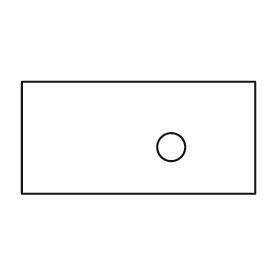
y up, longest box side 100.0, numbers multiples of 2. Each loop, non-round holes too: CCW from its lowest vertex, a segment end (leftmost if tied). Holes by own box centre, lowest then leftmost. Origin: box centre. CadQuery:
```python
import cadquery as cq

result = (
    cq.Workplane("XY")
    .moveTo(-50.0, -24.0)
    .lineTo(50.0, -24.0)
    .lineTo(50.0, 24.0)
    .lineTo(-50.0, 24.0)
    .close()
    .moveTo(14.0, -4.0)
    .circle(6.0)
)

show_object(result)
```